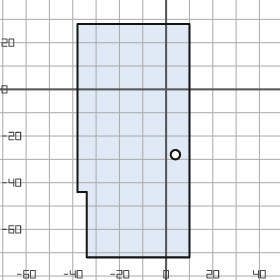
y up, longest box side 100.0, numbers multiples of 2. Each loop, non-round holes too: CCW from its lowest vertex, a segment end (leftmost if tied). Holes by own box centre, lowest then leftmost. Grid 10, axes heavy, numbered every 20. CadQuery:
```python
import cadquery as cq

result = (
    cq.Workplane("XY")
    .moveTo(-34.0, -72.0)
    .lineTo(10.0, -72.0)
    .lineTo(10.0, 28.0)
    .lineTo(-38.0, 28.0)
    .lineTo(-38.0, -44.0)
    .lineTo(-34.0, -44.0)
    .close()
    .moveTo(4.0, -28.0)
    .circle(2.0)
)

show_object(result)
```